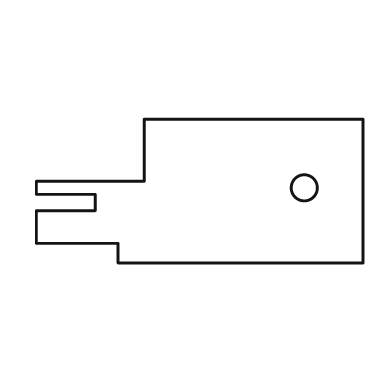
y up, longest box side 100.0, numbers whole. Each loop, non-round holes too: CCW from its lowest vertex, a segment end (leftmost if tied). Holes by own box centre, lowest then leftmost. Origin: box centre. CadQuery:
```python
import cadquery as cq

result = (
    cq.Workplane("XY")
    .moveTo(-25.0, -22.0)
    .lineTo(50.0, -22.0)
    .lineTo(50.0, 22.0)
    .lineTo(-17.0, 22.0)
    .lineTo(-17.0, 3.0)
    .lineTo(-50.0, 3.0)
    .lineTo(-50.0, -1.0)
    .lineTo(-32.0, -1.0)
    .lineTo(-32.0, -6.0)
    .lineTo(-50.0, -6.0)
    .lineTo(-50.0, -16.0)
    .lineTo(-25.0, -16.0)
    .close()
    .moveTo(32.0, 1.0)
    .circle(4.0)
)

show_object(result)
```